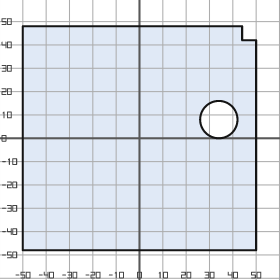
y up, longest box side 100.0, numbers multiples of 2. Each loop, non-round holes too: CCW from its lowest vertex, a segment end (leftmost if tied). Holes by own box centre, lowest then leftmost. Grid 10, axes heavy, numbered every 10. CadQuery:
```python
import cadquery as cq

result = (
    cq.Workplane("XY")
    .moveTo(-50.0, -48.0)
    .lineTo(50.0, -48.0)
    .lineTo(50.0, 42.0)
    .lineTo(44.0, 42.0)
    .lineTo(44.0, 48.0)
    .lineTo(-50.0, 48.0)
    .close()
    .moveTo(34.0, 8.0)
    .circle(8.0)
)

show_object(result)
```